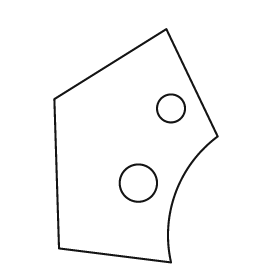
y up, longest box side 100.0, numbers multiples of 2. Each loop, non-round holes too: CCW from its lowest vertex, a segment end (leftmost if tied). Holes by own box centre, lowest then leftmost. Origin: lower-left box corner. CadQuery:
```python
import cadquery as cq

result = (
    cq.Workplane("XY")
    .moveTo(50.0, 0.0)
    .threePointArc((52.0, 30.0), (70.0, 54.0))
    .lineTo(48.0, 100.0)
    .lineTo(0.0, 70.0)
    .lineTo(2.0, 6.0)
    .close()
    .moveTo(36.0, 34.0)
    .circle(8.0)
    .moveTo(50.0, 66.0)
    .circle(6.0)
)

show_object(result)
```